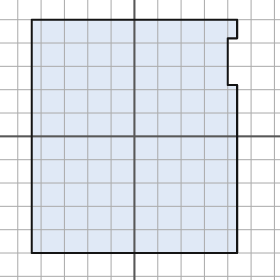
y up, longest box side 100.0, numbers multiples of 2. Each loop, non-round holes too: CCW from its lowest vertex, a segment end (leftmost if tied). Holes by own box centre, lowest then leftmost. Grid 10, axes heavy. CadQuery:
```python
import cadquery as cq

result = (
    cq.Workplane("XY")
    .moveTo(-44.0, -50.0)
    .lineTo(44.0, -50.0)
    .lineTo(44.0, 22.0)
    .lineTo(40.0, 22.0)
    .lineTo(40.0, 42.0)
    .lineTo(44.0, 42.0)
    .lineTo(44.0, 50.0)
    .lineTo(-44.0, 50.0)
    .close()
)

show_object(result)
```